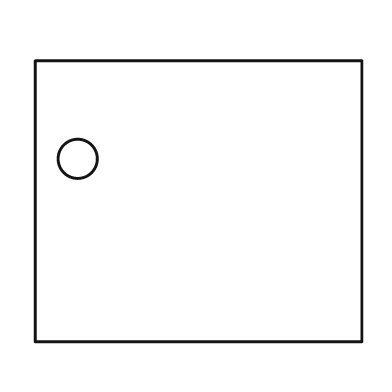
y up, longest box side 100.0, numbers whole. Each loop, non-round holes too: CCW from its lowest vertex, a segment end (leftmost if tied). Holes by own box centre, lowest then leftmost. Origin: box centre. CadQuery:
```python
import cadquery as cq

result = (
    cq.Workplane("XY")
    .moveTo(-50.0, -43.0)
    .lineTo(50.0, -43.0)
    .lineTo(50.0, 43.0)
    .lineTo(-50.0, 43.0)
    .close()
    .moveTo(-37.0, 13.0)
    .circle(6.0)
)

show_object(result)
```